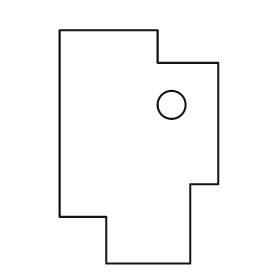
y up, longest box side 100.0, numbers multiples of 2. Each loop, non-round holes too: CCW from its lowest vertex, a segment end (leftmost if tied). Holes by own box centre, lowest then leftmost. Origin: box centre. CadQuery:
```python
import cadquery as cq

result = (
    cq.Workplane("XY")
    .moveTo(-14.0, -50.0)
    .lineTo(22.0, -50.0)
    .lineTo(22.0, -16.0)
    .lineTo(34.0, -16.0)
    .lineTo(34.0, 36.0)
    .lineTo(8.0, 36.0)
    .lineTo(8.0, 50.0)
    .lineTo(-34.0, 50.0)
    .lineTo(-34.0, -30.0)
    .lineTo(-14.0, -30.0)
    .close()
    .moveTo(14.0, 18.0)
    .circle(6.0)
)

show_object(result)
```